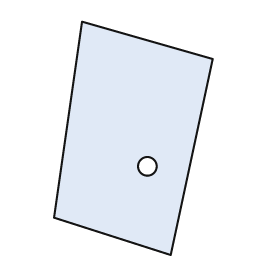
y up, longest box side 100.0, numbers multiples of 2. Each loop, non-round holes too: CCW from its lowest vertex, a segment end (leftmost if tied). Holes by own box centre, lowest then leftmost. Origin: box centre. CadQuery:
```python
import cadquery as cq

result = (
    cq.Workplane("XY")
    .moveTo(16.0, -50.0)
    .lineTo(34.0, 34.0)
    .lineTo(-22.0, 50.0)
    .lineTo(-34.0, -34.0)
    .close()
    .moveTo(6.0, -12.0)
    .circle(4.0)
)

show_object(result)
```